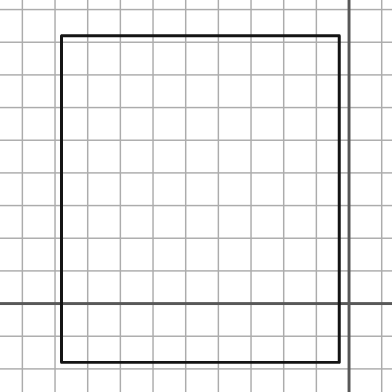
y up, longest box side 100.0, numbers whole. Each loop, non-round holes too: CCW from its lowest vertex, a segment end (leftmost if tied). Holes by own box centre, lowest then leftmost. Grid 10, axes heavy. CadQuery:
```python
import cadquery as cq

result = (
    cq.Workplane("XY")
    .moveTo(-88.0, -18.0)
    .lineTo(-3.0, -18.0)
    .lineTo(-3.0, 82.0)
    .lineTo(-88.0, 82.0)
    .close()
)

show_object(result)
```